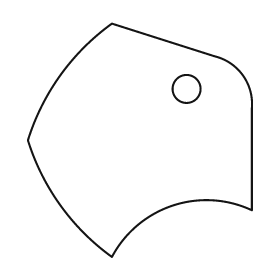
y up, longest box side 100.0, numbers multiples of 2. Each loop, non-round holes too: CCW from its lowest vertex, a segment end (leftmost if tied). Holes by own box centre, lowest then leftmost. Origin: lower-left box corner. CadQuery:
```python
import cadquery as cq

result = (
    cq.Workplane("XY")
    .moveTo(36.0, 0.0)
    .threePointArc((62.0, 22.0), (96.0, 20.0))
    .lineTo(96.0, 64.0)
    .threePointArc((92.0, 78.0), (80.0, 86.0))
    .lineTo(36.0, 100.0)
    .threePointArc((14.0, 78.0), (0.0, 50.0))
    .threePointArc((14.0, 22.0), (36.0, 0.0))
    .close()
    .moveTo(68.0, 72.0)
    .circle(6.0)
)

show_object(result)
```